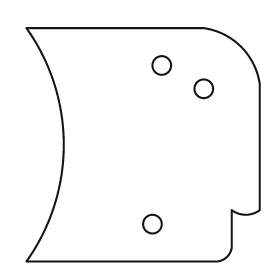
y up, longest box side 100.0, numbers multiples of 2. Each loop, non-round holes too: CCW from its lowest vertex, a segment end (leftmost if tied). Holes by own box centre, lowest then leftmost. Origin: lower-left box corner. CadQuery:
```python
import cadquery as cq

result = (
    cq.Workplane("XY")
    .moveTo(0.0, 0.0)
    .lineTo(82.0, 0.0)
    .threePointArc((86.0, 2.0), (88.0, 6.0))
    .lineTo(88.0, 22.0)
    .threePointArc((94.0, 20.0), (100.0, 22.0))
    .lineTo(100.0, 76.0)
    .threePointArc((92.0, 92.0), (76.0, 100.0))
    .lineTo(0.0, 100.0)
    .threePointArc((16.0, 50.0), (0.0, 0.0))
    .close()
    .moveTo(54.0, 16.0)
    .circle(4.0)
    .moveTo(76.0, 74.0)
    .circle(4.0)
    .moveTo(58.0, 84.0)
    .circle(4.0)
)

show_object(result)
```